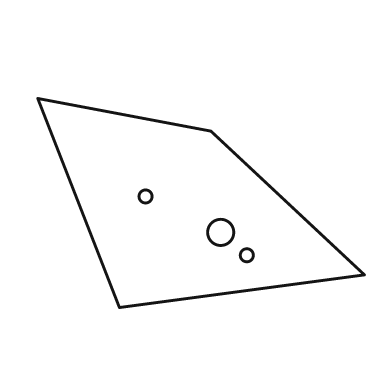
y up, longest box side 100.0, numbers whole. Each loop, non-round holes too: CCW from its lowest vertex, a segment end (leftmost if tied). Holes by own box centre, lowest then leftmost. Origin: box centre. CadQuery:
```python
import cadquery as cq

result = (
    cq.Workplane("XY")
    .moveTo(-25.0, -32.0)
    .lineTo(50.0, -22.0)
    .lineTo(3.0, 22.0)
    .lineTo(-50.0, 32.0)
    .close()
    .moveTo(14.0, -16.0)
    .circle(2.0)
    .moveTo(6.0, -9.0)
    .circle(4.0)
    .moveTo(-17.0, 2.0)
    .circle(2.0)
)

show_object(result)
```